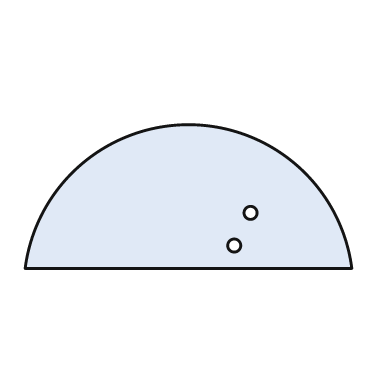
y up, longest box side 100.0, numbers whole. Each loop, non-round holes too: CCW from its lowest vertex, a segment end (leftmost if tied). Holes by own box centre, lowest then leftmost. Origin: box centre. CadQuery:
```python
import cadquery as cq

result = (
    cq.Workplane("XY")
    .moveTo(-50.0, -22.0)
    .lineTo(50.0, -22.0)
    .threePointArc((0.0, 22.0), (-50.0, -22.0))
    .close()
    .moveTo(14.0, -15.0)
    .circle(2.0)
    .moveTo(19.0, -5.0)
    .circle(2.0)
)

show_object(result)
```